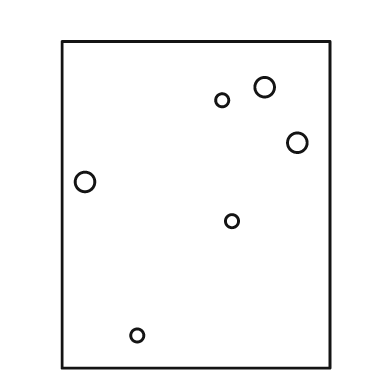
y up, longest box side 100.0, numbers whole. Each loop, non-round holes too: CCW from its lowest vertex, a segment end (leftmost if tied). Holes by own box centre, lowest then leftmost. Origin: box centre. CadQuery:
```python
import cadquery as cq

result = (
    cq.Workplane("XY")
    .moveTo(-41.0, -50.0)
    .lineTo(41.0, -50.0)
    .lineTo(41.0, 50.0)
    .lineTo(-41.0, 50.0)
    .close()
    .moveTo(-18.0, -40.0)
    .circle(2.0)
    .moveTo(11.0, -5.0)
    .circle(2.0)
    .moveTo(-34.0, 7.0)
    .circle(3.0)
    .moveTo(31.0, 19.0)
    .circle(3.0)
    .moveTo(8.0, 32.0)
    .circle(2.0)
    .moveTo(21.0, 36.0)
    .circle(3.0)
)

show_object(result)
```